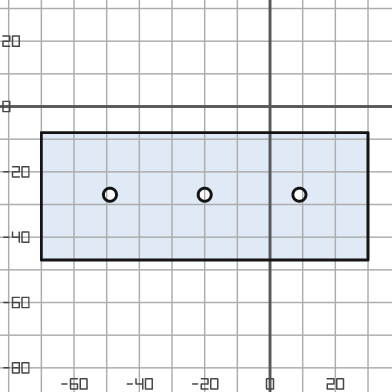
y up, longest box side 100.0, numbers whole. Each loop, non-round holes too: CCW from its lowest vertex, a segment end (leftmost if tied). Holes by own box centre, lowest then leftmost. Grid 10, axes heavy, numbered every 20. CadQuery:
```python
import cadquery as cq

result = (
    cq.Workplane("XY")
    .moveTo(-70.0, -47.0)
    .lineTo(30.0, -47.0)
    .lineTo(30.0, -8.0)
    .lineTo(-70.0, -8.0)
    .close()
    .moveTo(-49.0, -27.0)
    .circle(2.0)
    .moveTo(-20.0, -27.0)
    .circle(2.0)
    .moveTo(9.0, -27.0)
    .circle(2.0)
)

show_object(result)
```